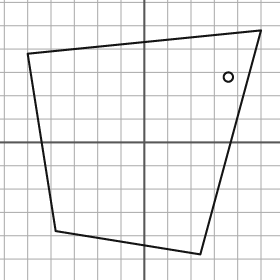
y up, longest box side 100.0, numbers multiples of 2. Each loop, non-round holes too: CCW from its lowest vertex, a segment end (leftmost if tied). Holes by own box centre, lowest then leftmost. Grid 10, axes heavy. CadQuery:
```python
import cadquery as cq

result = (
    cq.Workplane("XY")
    .moveTo(24.0, -48.0)
    .lineTo(50.0, 48.0)
    .lineTo(-50.0, 38.0)
    .lineTo(-38.0, -38.0)
    .close()
    .moveTo(36.0, 28.0)
    .circle(2.0)
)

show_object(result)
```